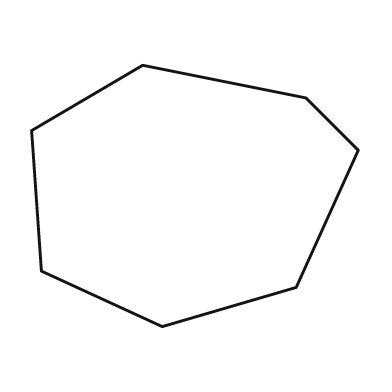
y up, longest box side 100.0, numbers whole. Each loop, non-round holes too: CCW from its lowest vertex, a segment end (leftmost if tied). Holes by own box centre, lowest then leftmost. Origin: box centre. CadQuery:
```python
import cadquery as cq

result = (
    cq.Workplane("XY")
    .moveTo(-10.0, -40.0)
    .lineTo(31.0, -28.0)
    .lineTo(50.0, 14.0)
    .lineTo(34.0, 30.0)
    .lineTo(-16.0, 40.0)
    .lineTo(-50.0, 20.0)
    .lineTo(-47.0, -23.0)
    .close()
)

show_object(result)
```